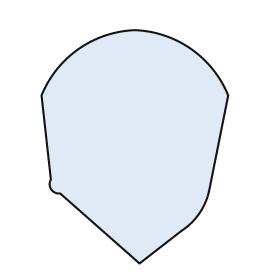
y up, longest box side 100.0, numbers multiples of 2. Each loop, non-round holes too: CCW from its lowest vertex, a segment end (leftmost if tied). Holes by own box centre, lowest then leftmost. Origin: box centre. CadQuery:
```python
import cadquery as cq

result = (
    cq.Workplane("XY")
    .moveTo(2.0, -50.0)
    .lineTo(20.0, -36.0)
    .threePointArc((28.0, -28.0), (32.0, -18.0))
    .lineTo(40.0, 22.0)
    .threePointArc((24.0, 42.0), (0.0, 50.0))
    .threePointArc((-24.0, 42.0), (-40.0, 22.0))
    .lineTo(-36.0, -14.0)
    .threePointArc((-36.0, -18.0), (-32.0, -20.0))
    .close()
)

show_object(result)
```